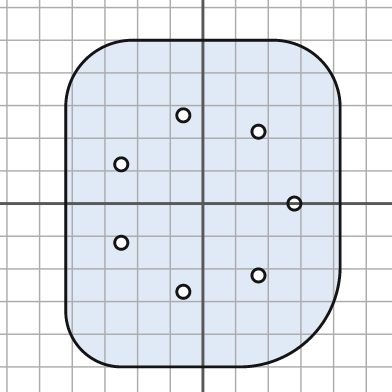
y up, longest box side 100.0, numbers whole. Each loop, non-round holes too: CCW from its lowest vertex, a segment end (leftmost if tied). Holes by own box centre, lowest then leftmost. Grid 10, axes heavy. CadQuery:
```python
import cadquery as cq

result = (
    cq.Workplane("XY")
    .moveTo(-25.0, -50.0)
    .lineTo(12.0, -50.0)
    .threePointArc((33.0, -41.0), (42.0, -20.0))
    .lineTo(42.0, 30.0)
    .threePointArc((36.0, 44.0), (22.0, 50.0))
    .lineTo(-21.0, 50.0)
    .threePointArc((-36.0, 44.0), (-42.0, 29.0))
    .lineTo(-42.0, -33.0)
    .threePointArc((-37.0, -45.0), (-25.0, -50.0))
    .close()
    .moveTo(-6.0, -27.0)
    .circle(2.0)
    .moveTo(17.0, -22.0)
    .circle(2.0)
    .moveTo(-25.0, -12.0)
    .circle(2.0)
    .moveTo(28.0, 0.0)
    .circle(2.0)
    .moveTo(-25.0, 12.0)
    .circle(2.0)
    .moveTo(17.0, 22.0)
    .circle(2.0)
    .moveTo(-6.0, 27.0)
    .circle(2.0)
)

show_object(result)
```